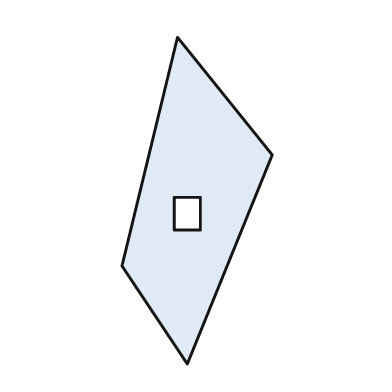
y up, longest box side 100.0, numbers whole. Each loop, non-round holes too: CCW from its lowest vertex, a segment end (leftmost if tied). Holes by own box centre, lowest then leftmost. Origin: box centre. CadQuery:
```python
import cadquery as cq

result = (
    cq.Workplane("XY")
    .moveTo(-3.0, -50.0)
    .lineTo(23.0, 14.0)
    .lineTo(-6.0, 50.0)
    .lineTo(-23.0, -20.0)
    .close()
    .moveTo(-7.0, -9.0)
    .lineTo(1.0, -9.0)
    .lineTo(1.0, 1.0)
    .lineTo(-7.0, 1.0)
    .close()
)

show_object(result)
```